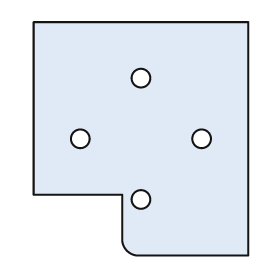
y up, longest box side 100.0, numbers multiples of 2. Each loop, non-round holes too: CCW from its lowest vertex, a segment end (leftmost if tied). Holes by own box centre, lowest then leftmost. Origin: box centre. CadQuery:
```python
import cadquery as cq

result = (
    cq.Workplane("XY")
    .moveTo(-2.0, -50.0)
    .lineTo(46.0, -50.0)
    .lineTo(46.0, 50.0)
    .lineTo(-46.0, 50.0)
    .lineTo(-46.0, -24.0)
    .lineTo(-8.0, -24.0)
    .lineTo(-8.0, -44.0)
    .threePointArc((-6.0, -48.0), (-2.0, -50.0))
    .close()
    .moveTo(0.0, -26.0)
    .circle(4.0)
    .moveTo(-26.0, 0.0)
    .circle(4.0)
    .moveTo(26.0, 0.0)
    .circle(4.0)
    .moveTo(0.0, 26.0)
    .circle(4.0)
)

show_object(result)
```